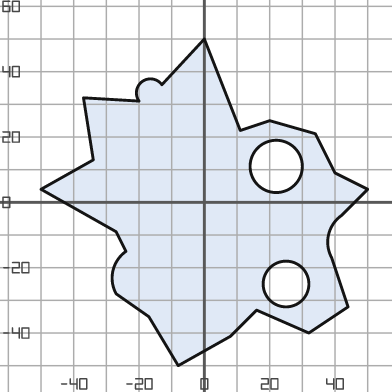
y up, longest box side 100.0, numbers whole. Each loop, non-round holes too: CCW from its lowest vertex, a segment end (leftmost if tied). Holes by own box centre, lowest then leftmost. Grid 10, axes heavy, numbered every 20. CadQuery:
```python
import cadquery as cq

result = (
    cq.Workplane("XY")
    .moveTo(-8.0, -50.0)
    .lineTo(8.0, -41.0)
    .lineTo(16.0, -33.0)
    .lineTo(32.0, -40.0)
    .lineTo(44.0, -32.0)
    .lineTo(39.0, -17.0)
    .threePointArc((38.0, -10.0), (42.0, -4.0))
    .lineTo(50.0, 4.0)
    .lineTo(40.0, 9.0)
    .lineTo(34.0, 21.0)
    .lineTo(20.0, 25.0)
    .lineTo(11.0, 22.0)
    .lineTo(0.0, 50.0)
    .lineTo(-13.0, 36.0)
    .threePointArc((-19.0, 37.0), (-20.0, 31.0))
    .lineTo(-37.0, 32.0)
    .lineTo(-34.0, 13.0)
    .lineTo(-50.0, 4.0)
    .lineTo(-27.0, -9.0)
    .lineTo(-24.0, -15.0)
    .threePointArc((-28.0, -21.0), (-27.0, -28.0))
    .lineTo(-17.0, -35.0)
    .close()
    .moveTo(25.0, -25.0)
    .circle(7.0)
    .moveTo(22.0, 11.0)
    .circle(8.0)
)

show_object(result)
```